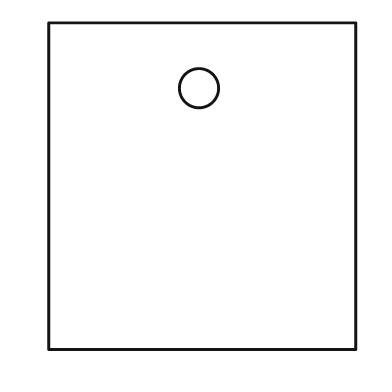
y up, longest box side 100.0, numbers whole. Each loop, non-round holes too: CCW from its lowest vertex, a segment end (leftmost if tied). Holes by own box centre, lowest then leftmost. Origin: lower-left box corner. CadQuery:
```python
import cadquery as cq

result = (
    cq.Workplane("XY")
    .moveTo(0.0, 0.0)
    .lineTo(94.0, 0.0)
    .lineTo(94.0, 100.0)
    .lineTo(0.0, 100.0)
    .close()
    .moveTo(46.0, 80.0)
    .circle(6.0)
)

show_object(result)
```